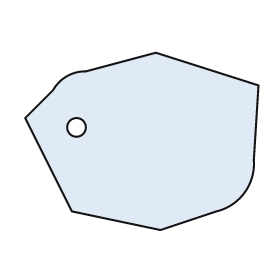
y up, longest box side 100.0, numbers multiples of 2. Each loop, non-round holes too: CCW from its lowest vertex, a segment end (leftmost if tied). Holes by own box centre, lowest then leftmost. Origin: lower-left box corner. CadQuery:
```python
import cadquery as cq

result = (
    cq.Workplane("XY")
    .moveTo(58.0, 0.0)
    .lineTo(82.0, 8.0)
    .threePointArc((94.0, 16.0), (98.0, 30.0))
    .lineTo(100.0, 62.0)
    .lineTo(56.0, 76.0)
    .lineTo(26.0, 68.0)
    .threePointArc((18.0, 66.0), (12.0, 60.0))
    .lineTo(0.0, 48.0)
    .lineTo(20.0, 8.0)
    .close()
    .moveTo(22.0, 44.0)
    .circle(4.0)
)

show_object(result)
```